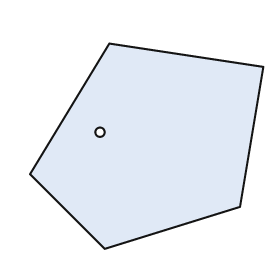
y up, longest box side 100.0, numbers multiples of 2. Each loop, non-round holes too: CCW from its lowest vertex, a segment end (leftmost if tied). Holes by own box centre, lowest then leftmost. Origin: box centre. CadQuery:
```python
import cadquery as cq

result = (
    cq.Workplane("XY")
    .moveTo(-18.0, -44.0)
    .lineTo(40.0, -26.0)
    .lineTo(50.0, 34.0)
    .lineTo(-16.0, 44.0)
    .lineTo(-50.0, -12.0)
    .close()
    .moveTo(-20.0, 6.0)
    .circle(2.0)
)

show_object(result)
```